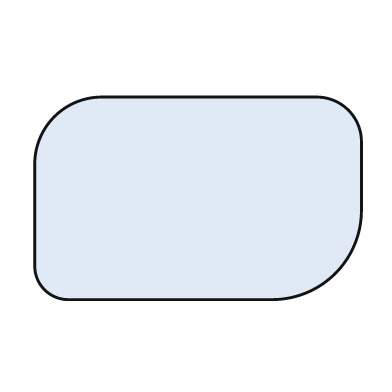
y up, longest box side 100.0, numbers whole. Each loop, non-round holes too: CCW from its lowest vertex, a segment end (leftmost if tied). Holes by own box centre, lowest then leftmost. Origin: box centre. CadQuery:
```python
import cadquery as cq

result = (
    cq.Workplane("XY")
    .moveTo(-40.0, -31.0)
    .lineTo(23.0, -31.0)
    .threePointArc((42.0, -23.0), (50.0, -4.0))
    .lineTo(50.0, 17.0)
    .threePointArc((46.0, 27.0), (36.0, 31.0))
    .lineTo(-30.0, 31.0)
    .threePointArc((-44.0, 25.0), (-50.0, 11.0))
    .lineTo(-50.0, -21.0)
    .threePointArc((-47.0, -28.0), (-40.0, -31.0))
    .close()
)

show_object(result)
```